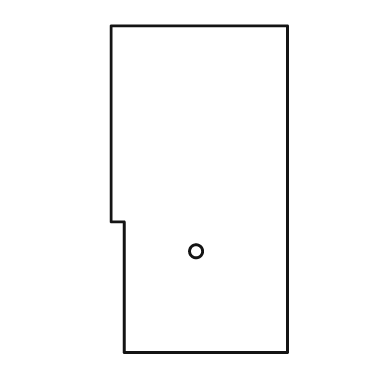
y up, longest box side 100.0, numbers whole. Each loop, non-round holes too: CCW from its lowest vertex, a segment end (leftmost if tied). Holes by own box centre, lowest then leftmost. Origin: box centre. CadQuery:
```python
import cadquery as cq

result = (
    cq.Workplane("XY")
    .moveTo(-23.0, -50.0)
    .lineTo(27.0, -50.0)
    .lineTo(27.0, 50.0)
    .lineTo(-27.0, 50.0)
    .lineTo(-27.0, -10.0)
    .lineTo(-23.0, -10.0)
    .close()
    .moveTo(-1.0, -19.0)
    .circle(2.0)
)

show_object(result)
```